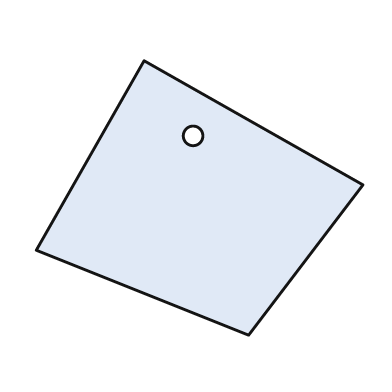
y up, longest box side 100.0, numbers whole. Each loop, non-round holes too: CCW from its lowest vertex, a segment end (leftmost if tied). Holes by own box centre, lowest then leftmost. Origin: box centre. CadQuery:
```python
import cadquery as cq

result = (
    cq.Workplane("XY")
    .moveTo(15.0, -42.0)
    .lineTo(50.0, 4.0)
    .lineTo(-17.0, 42.0)
    .lineTo(-50.0, -16.0)
    .close()
    .moveTo(-2.0, 19.0)
    .circle(3.0)
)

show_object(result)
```